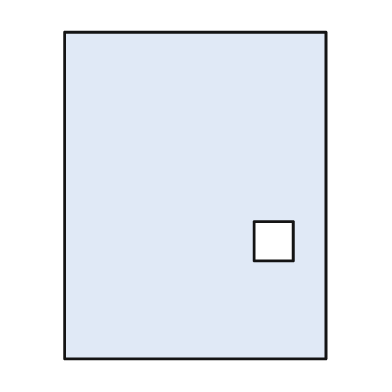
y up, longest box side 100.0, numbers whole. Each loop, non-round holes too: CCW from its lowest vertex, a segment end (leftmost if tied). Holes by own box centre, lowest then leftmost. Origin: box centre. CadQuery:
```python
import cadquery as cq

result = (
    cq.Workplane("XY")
    .moveTo(-40.0, -50.0)
    .lineTo(40.0, -50.0)
    .lineTo(40.0, 50.0)
    .lineTo(-40.0, 50.0)
    .close()
    .moveTo(18.0, -20.0)
    .lineTo(30.0, -20.0)
    .lineTo(30.0, -8.0)
    .lineTo(18.0, -8.0)
    .close()
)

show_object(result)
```